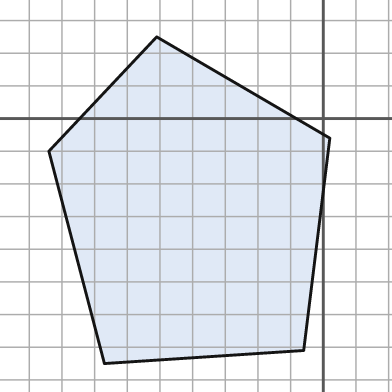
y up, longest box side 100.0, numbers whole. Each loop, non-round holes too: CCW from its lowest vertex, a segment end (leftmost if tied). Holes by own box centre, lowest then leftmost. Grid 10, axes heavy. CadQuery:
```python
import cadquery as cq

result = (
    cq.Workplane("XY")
    .moveTo(-67.0, -75.0)
    .lineTo(-6.0, -71.0)
    .lineTo(2.0, -6.0)
    .lineTo(-51.0, 25.0)
    .lineTo(-84.0, -10.0)
    .close()
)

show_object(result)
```